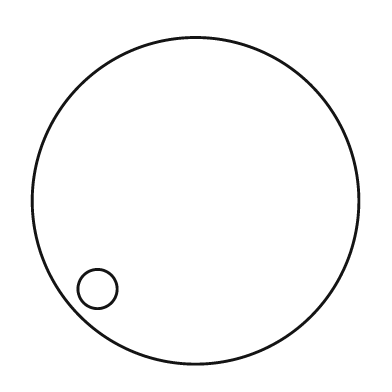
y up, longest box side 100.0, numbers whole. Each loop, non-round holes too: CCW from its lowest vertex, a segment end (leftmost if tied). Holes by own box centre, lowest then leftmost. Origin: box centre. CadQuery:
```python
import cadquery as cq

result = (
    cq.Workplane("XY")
    .moveTo(0.0, 0.0)
    .circle(50.0)
    .moveTo(-30.0, -27.0)
    .circle(6.0)
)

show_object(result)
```